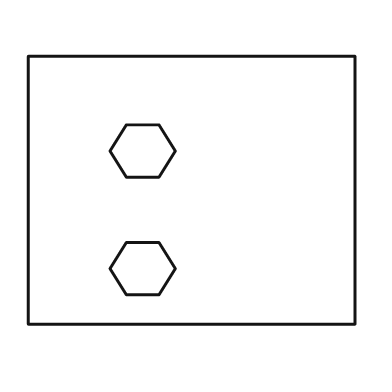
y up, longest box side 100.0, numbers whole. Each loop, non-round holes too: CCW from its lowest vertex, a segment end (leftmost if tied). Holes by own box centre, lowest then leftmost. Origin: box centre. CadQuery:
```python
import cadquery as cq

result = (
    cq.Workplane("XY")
    .moveTo(-50.0, -41.0)
    .lineTo(50.0, -41.0)
    .lineTo(50.0, 41.0)
    .lineTo(-50.0, 41.0)
    .close()
    .moveTo(-20.0, -32.0)
    .lineTo(-10.0, -32.0)
    .lineTo(-5.0, -24.0)
    .lineTo(-10.0, -16.0)
    .lineTo(-20.0, -16.0)
    .lineTo(-25.0, -24.0)
    .close()
    .moveTo(-20.0, 4.0)
    .lineTo(-10.0, 4.0)
    .lineTo(-5.0, 12.0)
    .lineTo(-10.0, 20.0)
    .lineTo(-20.0, 20.0)
    .lineTo(-25.0, 12.0)
    .close()
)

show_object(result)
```